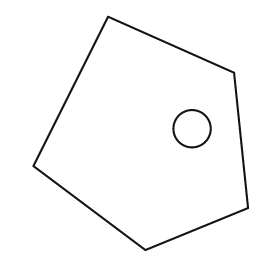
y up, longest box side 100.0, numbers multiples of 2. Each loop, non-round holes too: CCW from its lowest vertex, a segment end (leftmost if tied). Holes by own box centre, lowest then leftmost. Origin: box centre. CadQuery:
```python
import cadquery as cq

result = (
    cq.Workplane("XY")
    .moveTo(2.0, -50.0)
    .lineTo(46.0, -32.0)
    .lineTo(40.0, 26.0)
    .lineTo(-14.0, 50.0)
    .lineTo(-46.0, -14.0)
    .close()
    .moveTo(22.0, 2.0)
    .circle(8.0)
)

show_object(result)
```